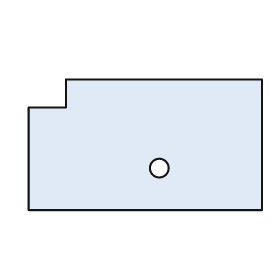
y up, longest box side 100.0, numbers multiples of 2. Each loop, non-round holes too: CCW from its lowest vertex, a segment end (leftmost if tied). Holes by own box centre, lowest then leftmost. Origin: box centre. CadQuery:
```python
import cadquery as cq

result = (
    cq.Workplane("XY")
    .moveTo(-50.0, -28.0)
    .lineTo(50.0, -28.0)
    .lineTo(50.0, 28.0)
    .lineTo(-34.0, 28.0)
    .lineTo(-34.0, 16.0)
    .lineTo(-50.0, 16.0)
    .close()
    .moveTo(6.0, -10.0)
    .circle(4.0)
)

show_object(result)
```